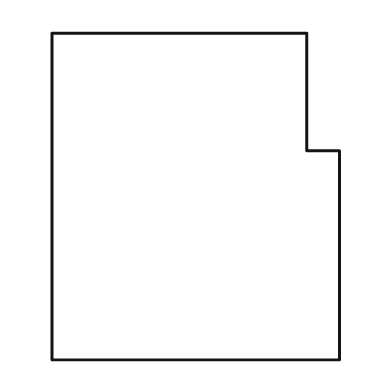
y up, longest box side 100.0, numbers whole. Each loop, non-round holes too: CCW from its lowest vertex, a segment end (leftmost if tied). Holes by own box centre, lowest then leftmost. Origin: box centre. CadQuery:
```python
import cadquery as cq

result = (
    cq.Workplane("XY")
    .moveTo(-44.0, -50.0)
    .lineTo(44.0, -50.0)
    .lineTo(44.0, 14.0)
    .lineTo(34.0, 14.0)
    .lineTo(34.0, 50.0)
    .lineTo(-44.0, 50.0)
    .close()
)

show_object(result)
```